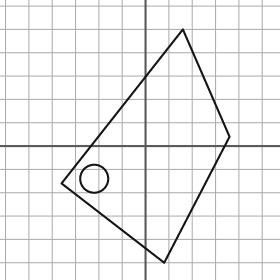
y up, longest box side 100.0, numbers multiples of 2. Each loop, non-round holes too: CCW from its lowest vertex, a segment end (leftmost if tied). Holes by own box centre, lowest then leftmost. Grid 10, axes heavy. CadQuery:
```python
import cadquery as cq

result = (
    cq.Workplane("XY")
    .moveTo(8.0, -50.0)
    .lineTo(36.0, 4.0)
    .lineTo(16.0, 50.0)
    .lineTo(-36.0, -16.0)
    .close()
    .moveTo(-22.0, -14.0)
    .circle(6.0)
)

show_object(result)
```